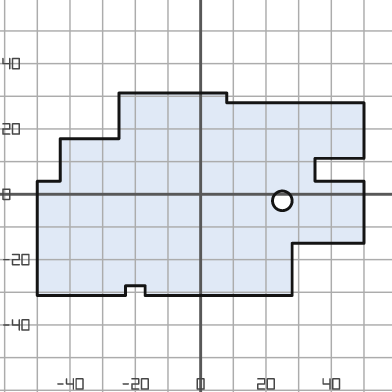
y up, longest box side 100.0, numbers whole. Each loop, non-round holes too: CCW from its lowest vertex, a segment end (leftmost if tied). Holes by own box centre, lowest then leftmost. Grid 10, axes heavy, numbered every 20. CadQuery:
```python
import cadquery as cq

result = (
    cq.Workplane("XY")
    .moveTo(-50.0, -31.0)
    .lineTo(-23.0, -31.0)
    .lineTo(-23.0, -28.0)
    .lineTo(-17.0, -28.0)
    .lineTo(-17.0, -31.0)
    .lineTo(28.0, -31.0)
    .lineTo(28.0, -15.0)
    .lineTo(50.0, -15.0)
    .lineTo(50.0, 4.0)
    .lineTo(35.0, 4.0)
    .lineTo(35.0, 11.0)
    .lineTo(50.0, 11.0)
    .lineTo(50.0, 28.0)
    .lineTo(8.0, 28.0)
    .lineTo(8.0, 31.0)
    .lineTo(-25.0, 31.0)
    .lineTo(-25.0, 17.0)
    .lineTo(-43.0, 17.0)
    .lineTo(-43.0, 4.0)
    .lineTo(-50.0, 4.0)
    .close()
    .moveTo(25.0, -2.0)
    .circle(3.0)
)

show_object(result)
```